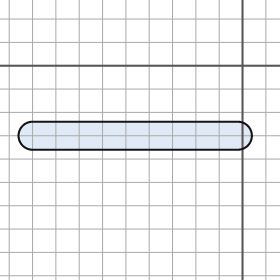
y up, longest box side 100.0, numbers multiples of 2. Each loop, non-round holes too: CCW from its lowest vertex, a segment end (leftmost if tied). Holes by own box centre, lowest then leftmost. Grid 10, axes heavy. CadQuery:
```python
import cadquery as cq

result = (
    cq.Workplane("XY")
    .moveTo(-90.0, -36.0)
    .lineTo(-2.0, -36.0)
    .threePointArc((4.0, -30.0), (-2.0, -24.0))
    .lineTo(-90.0, -24.0)
    .threePointArc((-96.0, -30.0), (-90.0, -36.0))
    .close()
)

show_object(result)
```